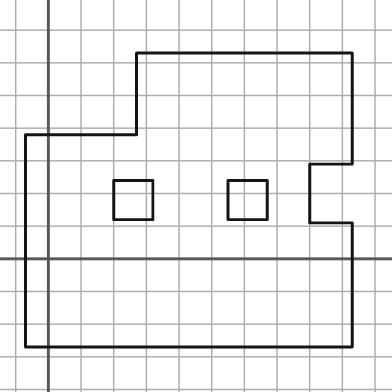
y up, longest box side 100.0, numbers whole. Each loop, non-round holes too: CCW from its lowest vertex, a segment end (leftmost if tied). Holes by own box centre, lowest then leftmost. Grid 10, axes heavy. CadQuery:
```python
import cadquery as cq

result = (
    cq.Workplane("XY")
    .moveTo(-7.0, -27.0)
    .lineTo(93.0, -27.0)
    .lineTo(93.0, 11.0)
    .lineTo(80.0, 11.0)
    .lineTo(80.0, 29.0)
    .lineTo(93.0, 29.0)
    .lineTo(93.0, 63.0)
    .lineTo(27.0, 63.0)
    .lineTo(27.0, 38.0)
    .lineTo(-7.0, 38.0)
    .close()
    .moveTo(20.0, 12.0)
    .lineTo(32.0, 12.0)
    .lineTo(32.0, 24.0)
    .lineTo(20.0, 24.0)
    .close()
    .moveTo(55.0, 12.0)
    .lineTo(67.0, 12.0)
    .lineTo(67.0, 24.0)
    .lineTo(55.0, 24.0)
    .close()
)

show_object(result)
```